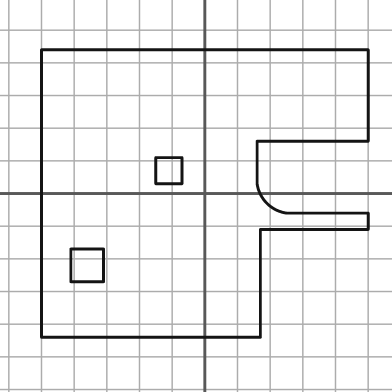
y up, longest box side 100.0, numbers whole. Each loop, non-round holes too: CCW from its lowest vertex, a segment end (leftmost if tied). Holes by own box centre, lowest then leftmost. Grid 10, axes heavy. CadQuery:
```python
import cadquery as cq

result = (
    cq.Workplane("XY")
    .moveTo(-50.0, -44.0)
    .lineTo(17.0, -44.0)
    .lineTo(17.0, -11.0)
    .lineTo(50.0, -11.0)
    .lineTo(50.0, -6.0)
    .lineTo(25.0, -6.0)
    .threePointArc((19.0, -3.0), (16.0, 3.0))
    .lineTo(16.0, 16.0)
    .lineTo(50.0, 16.0)
    .lineTo(50.0, 44.0)
    .lineTo(-50.0, 44.0)
    .close()
    .moveTo(-41.0, -27.0)
    .lineTo(-31.0, -27.0)
    .lineTo(-31.0, -17.0)
    .lineTo(-41.0, -17.0)
    .close()
    .moveTo(-15.0, 3.0)
    .lineTo(-7.0, 3.0)
    .lineTo(-7.0, 11.0)
    .lineTo(-15.0, 11.0)
    .close()
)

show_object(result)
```